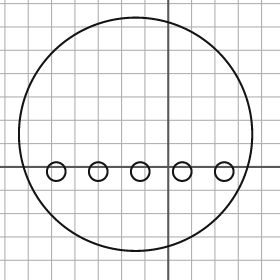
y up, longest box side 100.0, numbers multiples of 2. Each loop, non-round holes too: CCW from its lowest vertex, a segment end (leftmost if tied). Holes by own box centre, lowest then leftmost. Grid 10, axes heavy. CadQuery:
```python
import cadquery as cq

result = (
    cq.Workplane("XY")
    .moveTo(-14.0, 14.0)
    .circle(50.0)
    .moveTo(-48.0, -2.0)
    .circle(4.0)
    .moveTo(-30.0, -2.0)
    .circle(4.0)
    .moveTo(-12.0, -2.0)
    .circle(4.0)
    .moveTo(6.0, -2.0)
    .circle(4.0)
    .moveTo(24.0, -2.0)
    .circle(4.0)
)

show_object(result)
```